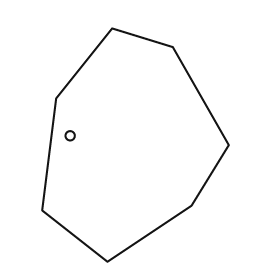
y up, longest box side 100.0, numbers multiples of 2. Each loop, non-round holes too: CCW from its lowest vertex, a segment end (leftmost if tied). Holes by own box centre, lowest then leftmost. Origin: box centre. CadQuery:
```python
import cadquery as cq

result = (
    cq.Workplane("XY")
    .moveTo(-12.0, -50.0)
    .lineTo(24.0, -26.0)
    .lineTo(40.0, 0.0)
    .lineTo(16.0, 42.0)
    .lineTo(-10.0, 50.0)
    .lineTo(-34.0, 20.0)
    .lineTo(-40.0, -28.0)
    .close()
    .moveTo(-28.0, 4.0)
    .circle(2.0)
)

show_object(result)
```